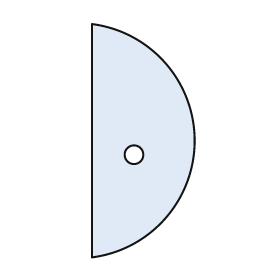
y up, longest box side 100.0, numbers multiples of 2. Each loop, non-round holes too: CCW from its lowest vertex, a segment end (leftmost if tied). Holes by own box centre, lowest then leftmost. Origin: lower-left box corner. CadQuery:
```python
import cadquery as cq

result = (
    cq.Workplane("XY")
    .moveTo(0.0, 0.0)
    .threePointArc((44.0, 50.0), (0.0, 100.0))
    .close()
    .moveTo(18.0, 44.0)
    .circle(4.0)
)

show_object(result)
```